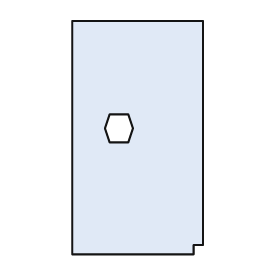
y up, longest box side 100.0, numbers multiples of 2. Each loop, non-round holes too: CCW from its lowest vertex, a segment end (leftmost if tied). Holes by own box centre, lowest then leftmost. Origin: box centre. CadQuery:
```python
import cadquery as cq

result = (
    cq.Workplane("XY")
    .moveTo(-28.0, -50.0)
    .lineTo(24.0, -50.0)
    .lineTo(24.0, -46.0)
    .lineTo(28.0, -46.0)
    .lineTo(28.0, 50.0)
    .lineTo(-28.0, 50.0)
    .close()
    .moveTo(-12.0, -2.0)
    .lineTo(-4.0, -2.0)
    .lineTo(-2.0, 4.0)
    .lineTo(-4.0, 10.0)
    .lineTo(-12.0, 10.0)
    .lineTo(-14.0, 4.0)
    .close()
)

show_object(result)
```